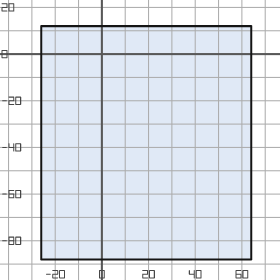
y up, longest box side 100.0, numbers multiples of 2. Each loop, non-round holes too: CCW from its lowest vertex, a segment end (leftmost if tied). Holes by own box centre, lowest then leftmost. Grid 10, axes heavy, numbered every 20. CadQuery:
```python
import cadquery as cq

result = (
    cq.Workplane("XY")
    .moveTo(-26.0, -88.0)
    .lineTo(64.0, -88.0)
    .lineTo(64.0, 12.0)
    .lineTo(-26.0, 12.0)
    .close()
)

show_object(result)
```